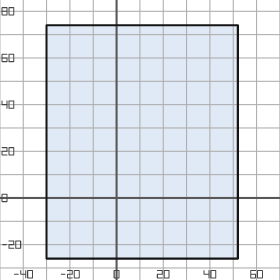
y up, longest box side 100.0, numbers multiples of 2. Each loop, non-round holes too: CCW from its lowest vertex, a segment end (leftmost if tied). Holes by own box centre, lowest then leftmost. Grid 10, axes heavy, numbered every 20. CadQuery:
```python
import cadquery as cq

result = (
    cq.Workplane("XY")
    .moveTo(-30.0, -26.0)
    .lineTo(52.0, -26.0)
    .lineTo(52.0, 74.0)
    .lineTo(-30.0, 74.0)
    .close()
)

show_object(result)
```